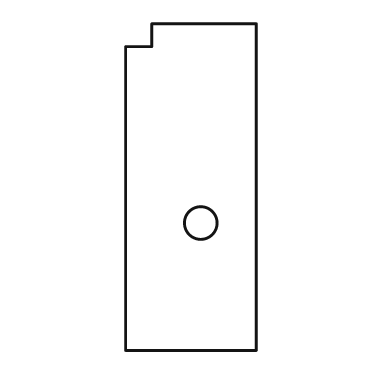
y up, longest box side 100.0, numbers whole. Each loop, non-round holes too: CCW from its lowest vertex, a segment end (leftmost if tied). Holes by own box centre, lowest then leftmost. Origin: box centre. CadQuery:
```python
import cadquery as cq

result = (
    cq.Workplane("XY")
    .moveTo(-20.0, -50.0)
    .lineTo(20.0, -50.0)
    .lineTo(20.0, 50.0)
    .lineTo(-12.0, 50.0)
    .lineTo(-12.0, 43.0)
    .lineTo(-20.0, 43.0)
    .close()
    .moveTo(3.0, -11.0)
    .circle(5.0)
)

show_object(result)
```